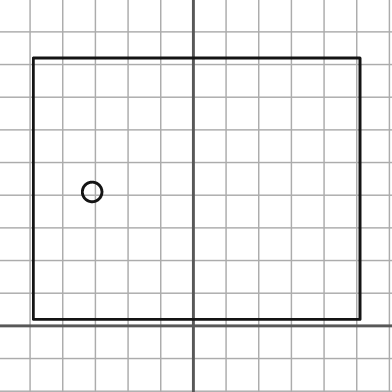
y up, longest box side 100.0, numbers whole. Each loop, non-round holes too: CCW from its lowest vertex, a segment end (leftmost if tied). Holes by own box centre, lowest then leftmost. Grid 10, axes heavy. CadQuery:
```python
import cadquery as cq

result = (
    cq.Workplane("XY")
    .moveTo(-49.0, 2.0)
    .lineTo(51.0, 2.0)
    .lineTo(51.0, 82.0)
    .lineTo(-49.0, 82.0)
    .close()
    .moveTo(-31.0, 41.0)
    .circle(3.0)
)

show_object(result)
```